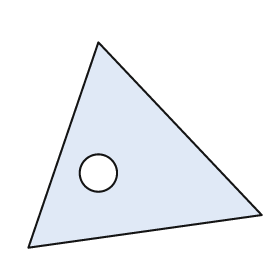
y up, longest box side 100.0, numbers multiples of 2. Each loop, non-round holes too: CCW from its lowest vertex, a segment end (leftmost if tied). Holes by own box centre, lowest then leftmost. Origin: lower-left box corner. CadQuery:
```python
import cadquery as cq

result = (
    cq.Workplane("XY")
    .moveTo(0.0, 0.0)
    .lineTo(100.0, 14.0)
    .lineTo(30.0, 88.0)
    .close()
    .moveTo(30.0, 32.0)
    .circle(8.0)
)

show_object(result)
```